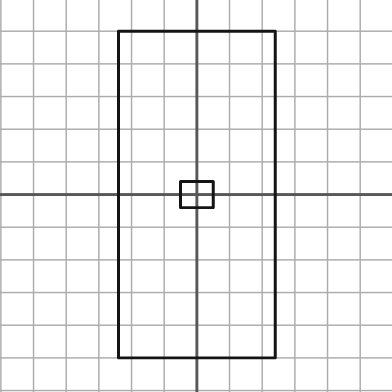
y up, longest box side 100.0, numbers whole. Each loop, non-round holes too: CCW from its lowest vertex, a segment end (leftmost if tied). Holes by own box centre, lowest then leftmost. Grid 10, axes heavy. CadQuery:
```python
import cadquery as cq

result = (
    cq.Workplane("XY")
    .moveTo(-24.0, -50.0)
    .lineTo(24.0, -50.0)
    .lineTo(24.0, 50.0)
    .lineTo(-24.0, 50.0)
    .close()
    .moveTo(-5.0, -4.0)
    .lineTo(5.0, -4.0)
    .lineTo(5.0, 4.0)
    .lineTo(-5.0, 4.0)
    .close()
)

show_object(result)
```